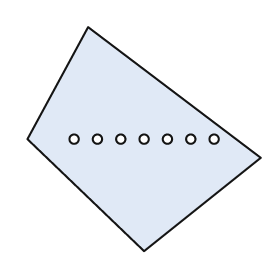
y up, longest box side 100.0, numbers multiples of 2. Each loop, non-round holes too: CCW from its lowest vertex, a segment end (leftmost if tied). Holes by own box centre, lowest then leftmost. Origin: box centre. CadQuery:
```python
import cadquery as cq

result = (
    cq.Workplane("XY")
    .moveTo(0.0, -48.0)
    .lineTo(50.0, -8.0)
    .lineTo(-24.0, 48.0)
    .lineTo(-50.0, 0.0)
    .close()
    .moveTo(-30.0, 0.0)
    .circle(2.0)
    .moveTo(-20.0, 0.0)
    .circle(2.0)
    .moveTo(-10.0, 0.0)
    .circle(2.0)
    .moveTo(0.0, 0.0)
    .circle(2.0)
    .moveTo(10.0, 0.0)
    .circle(2.0)
    .moveTo(20.0, 0.0)
    .circle(2.0)
    .moveTo(30.0, 0.0)
    .circle(2.0)
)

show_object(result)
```